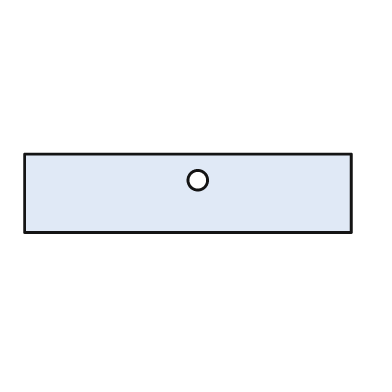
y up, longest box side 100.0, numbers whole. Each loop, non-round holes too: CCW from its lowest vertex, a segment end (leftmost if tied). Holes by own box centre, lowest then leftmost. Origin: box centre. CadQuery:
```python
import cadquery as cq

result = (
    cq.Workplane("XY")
    .moveTo(-50.0, -12.0)
    .lineTo(50.0, -12.0)
    .lineTo(50.0, 12.0)
    .lineTo(-50.0, 12.0)
    .close()
    .moveTo(3.0, 4.0)
    .circle(3.0)
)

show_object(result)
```